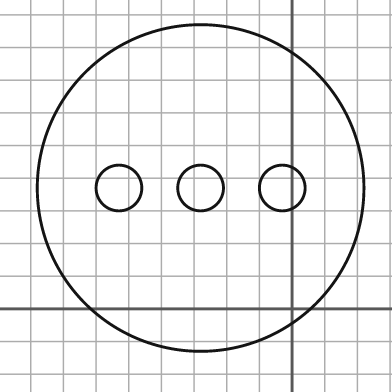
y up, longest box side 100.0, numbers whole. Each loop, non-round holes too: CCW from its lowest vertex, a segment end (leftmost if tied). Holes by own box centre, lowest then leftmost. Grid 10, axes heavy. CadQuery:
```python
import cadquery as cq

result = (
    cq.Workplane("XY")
    .moveTo(-28.0, 37.0)
    .circle(50.0)
    .moveTo(-53.0, 37.0)
    .circle(7.0)
    .moveTo(-28.0, 37.0)
    .circle(7.0)
    .moveTo(-3.0, 37.0)
    .circle(7.0)
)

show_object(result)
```